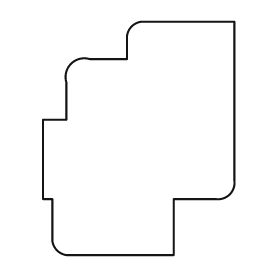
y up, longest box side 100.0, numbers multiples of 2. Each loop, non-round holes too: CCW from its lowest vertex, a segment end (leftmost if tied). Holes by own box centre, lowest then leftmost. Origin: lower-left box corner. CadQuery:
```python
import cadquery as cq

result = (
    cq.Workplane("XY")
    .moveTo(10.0, 0.0)
    .lineTo(56.0, 0.0)
    .lineTo(56.0, 24.0)
    .lineTo(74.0, 24.0)
    .threePointArc((80.0, 26.0), (82.0, 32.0))
    .lineTo(82.0, 100.0)
    .lineTo(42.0, 100.0)
    .threePointArc((38.0, 98.0), (36.0, 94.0))
    .lineTo(36.0, 84.0)
    .lineTo(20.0, 84.0)
    .threePointArc((12.0, 82.0), (10.0, 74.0))
    .lineTo(10.0, 58.0)
    .lineTo(0.0, 58.0)
    .lineTo(0.0, 24.0)
    .lineTo(4.0, 24.0)
    .lineTo(4.0, 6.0)
    .threePointArc((6.0, 2.0), (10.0, 0.0))
    .close()
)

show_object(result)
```